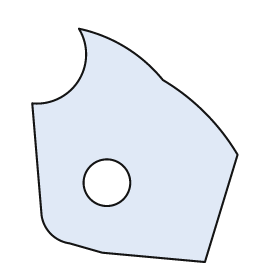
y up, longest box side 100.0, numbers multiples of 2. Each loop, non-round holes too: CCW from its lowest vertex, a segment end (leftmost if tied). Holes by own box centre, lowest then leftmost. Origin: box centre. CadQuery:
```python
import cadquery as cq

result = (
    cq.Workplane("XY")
    .moveTo(30.0, -50.0)
    .lineTo(44.0, -4.0)
    .threePointArc((30.0, 14.0), (12.0, 28.0))
    .threePointArc((-4.0, 42.0), (-24.0, 50.0))
    .threePointArc((-24.0, 28.0), (-44.0, 18.0))
    .lineTo(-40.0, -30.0)
    .threePointArc((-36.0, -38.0), (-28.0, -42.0))
    .lineTo(-14.0, -46.0)
    .close()
    .moveTo(-12.0, -16.0)
    .circle(10.0)
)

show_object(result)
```